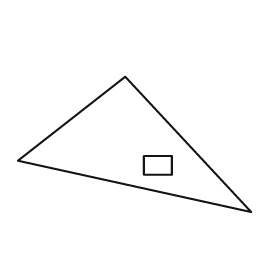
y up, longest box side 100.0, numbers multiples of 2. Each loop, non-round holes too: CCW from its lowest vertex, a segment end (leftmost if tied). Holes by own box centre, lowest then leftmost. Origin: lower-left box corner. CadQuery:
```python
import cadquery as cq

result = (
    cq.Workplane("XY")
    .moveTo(100.0, 0.0)
    .lineTo(46.0, 58.0)
    .lineTo(0.0, 22.0)
    .close()
    .moveTo(54.0, 16.0)
    .lineTo(66.0, 16.0)
    .lineTo(66.0, 24.0)
    .lineTo(54.0, 24.0)
    .close()
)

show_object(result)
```